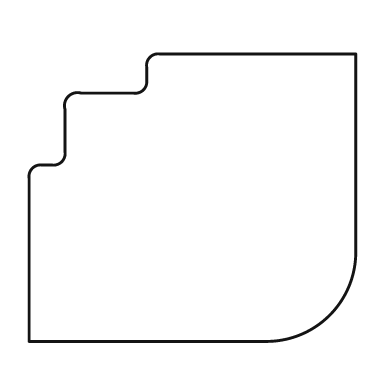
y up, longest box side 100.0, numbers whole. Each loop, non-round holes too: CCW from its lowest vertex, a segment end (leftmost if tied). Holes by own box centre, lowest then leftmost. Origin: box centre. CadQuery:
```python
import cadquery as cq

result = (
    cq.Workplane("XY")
    .moveTo(-50.0, -44.0)
    .lineTo(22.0, -44.0)
    .threePointArc((42.0, -36.0), (50.0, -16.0))
    .lineTo(50.0, 44.0)
    .lineTo(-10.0, 44.0)
    .threePointArc((-13.0, 43.0), (-14.0, 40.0))
    .lineTo(-14.0, 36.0)
    .threePointArc((-15.0, 33.0), (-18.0, 32.0))
    .lineTo(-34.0, 32.0)
    .threePointArc((-38.0, 31.0), (-39.0, 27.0))
    .lineTo(-39.0, 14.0)
    .threePointArc((-40.0, 11.0), (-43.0, 10.0))
    .lineTo(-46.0, 10.0)
    .threePointArc((-49.0, 9.0), (-50.0, 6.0))
    .close()
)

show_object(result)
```